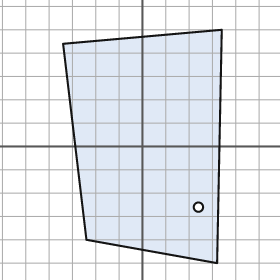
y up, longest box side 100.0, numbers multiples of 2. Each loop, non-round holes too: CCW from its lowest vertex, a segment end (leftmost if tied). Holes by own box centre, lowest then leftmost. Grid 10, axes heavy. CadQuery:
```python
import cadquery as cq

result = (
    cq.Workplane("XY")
    .moveTo(32.0, -50.0)
    .lineTo(34.0, 50.0)
    .lineTo(-34.0, 44.0)
    .lineTo(-24.0, -40.0)
    .close()
    .moveTo(24.0, -26.0)
    .circle(2.0)
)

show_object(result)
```